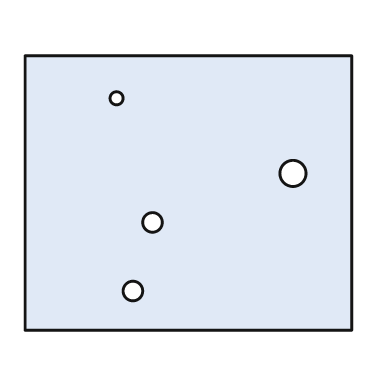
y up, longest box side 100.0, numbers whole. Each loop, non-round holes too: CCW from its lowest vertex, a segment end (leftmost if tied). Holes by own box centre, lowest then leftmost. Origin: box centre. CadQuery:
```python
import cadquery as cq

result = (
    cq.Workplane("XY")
    .moveTo(-50.0, -42.0)
    .lineTo(50.0, -42.0)
    .lineTo(50.0, 42.0)
    .lineTo(-50.0, 42.0)
    .close()
    .moveTo(-17.0, -30.0)
    .circle(3.0)
    .moveTo(-11.0, -9.0)
    .circle(3.0)
    .moveTo(32.0, 6.0)
    .circle(4.0)
    .moveTo(-22.0, 29.0)
    .circle(2.0)
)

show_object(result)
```